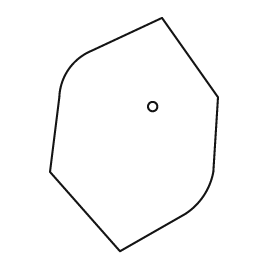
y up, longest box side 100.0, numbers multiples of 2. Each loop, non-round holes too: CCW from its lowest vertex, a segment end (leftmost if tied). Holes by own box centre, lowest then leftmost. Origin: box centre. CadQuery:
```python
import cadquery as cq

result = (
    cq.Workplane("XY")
    .moveTo(-6.0, -50.0)
    .lineTo(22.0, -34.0)
    .threePointArc((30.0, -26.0), (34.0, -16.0))
    .lineTo(36.0, 16.0)
    .lineTo(12.0, 50.0)
    .lineTo(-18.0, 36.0)
    .threePointArc((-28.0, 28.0), (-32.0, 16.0))
    .lineTo(-36.0, -16.0)
    .close()
    .moveTo(8.0, 12.0)
    .circle(2.0)
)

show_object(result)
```